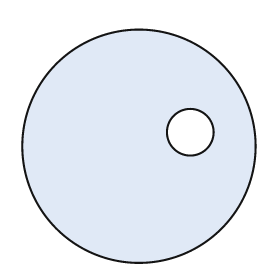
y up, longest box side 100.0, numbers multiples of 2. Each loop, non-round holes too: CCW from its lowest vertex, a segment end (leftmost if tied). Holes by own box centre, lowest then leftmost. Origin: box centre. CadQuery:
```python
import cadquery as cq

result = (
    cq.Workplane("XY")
    .moveTo(0.0, 0.0)
    .circle(50.0)
    .moveTo(22.0, 6.0)
    .circle(10.0)
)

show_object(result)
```